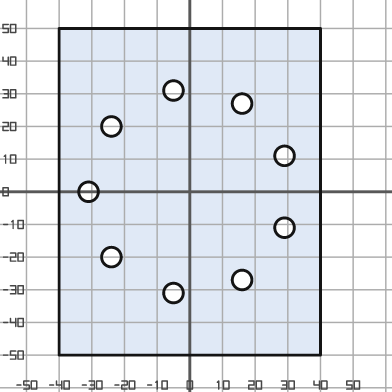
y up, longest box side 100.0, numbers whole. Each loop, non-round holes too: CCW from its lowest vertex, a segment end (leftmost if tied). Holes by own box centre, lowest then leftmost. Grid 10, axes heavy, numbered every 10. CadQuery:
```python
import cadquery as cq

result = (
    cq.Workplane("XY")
    .moveTo(-40.0, -50.0)
    .lineTo(40.0, -50.0)
    .lineTo(40.0, 50.0)
    .lineTo(-40.0, 50.0)
    .close()
    .moveTo(-5.0, -31.0)
    .circle(3.0)
    .moveTo(16.0, -27.0)
    .circle(3.0)
    .moveTo(-24.0, -20.0)
    .circle(3.0)
    .moveTo(29.0, -11.0)
    .circle(3.0)
    .moveTo(-31.0, 0.0)
    .circle(3.0)
    .moveTo(29.0, 11.0)
    .circle(3.0)
    .moveTo(-24.0, 20.0)
    .circle(3.0)
    .moveTo(16.0, 27.0)
    .circle(3.0)
    .moveTo(-5.0, 31.0)
    .circle(3.0)
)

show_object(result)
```